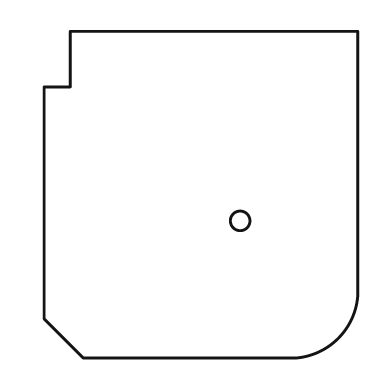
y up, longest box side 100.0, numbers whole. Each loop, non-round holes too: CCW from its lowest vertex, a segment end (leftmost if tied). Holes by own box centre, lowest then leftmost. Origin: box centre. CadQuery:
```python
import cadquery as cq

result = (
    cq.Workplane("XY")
    .moveTo(-36.0, -50.0)
    .lineTo(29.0, -50.0)
    .threePointArc((42.0, -44.0), (48.0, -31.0))
    .lineTo(48.0, 50.0)
    .lineTo(-40.0, 50.0)
    .lineTo(-40.0, 33.0)
    .lineTo(-48.0, 33.0)
    .lineTo(-48.0, -38.0)
    .close()
    .moveTo(12.0, -8.0)
    .circle(3.0)
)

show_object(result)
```